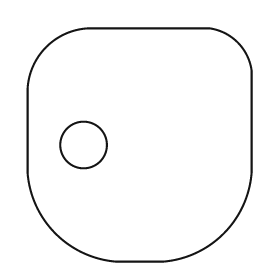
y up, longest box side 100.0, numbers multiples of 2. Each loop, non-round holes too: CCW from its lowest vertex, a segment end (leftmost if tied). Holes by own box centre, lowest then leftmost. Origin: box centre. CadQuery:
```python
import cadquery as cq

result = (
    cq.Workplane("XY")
    .moveTo(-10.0, -50.0)
    .lineTo(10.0, -50.0)
    .threePointArc((36.0, -38.0), (48.0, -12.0))
    .lineTo(48.0, 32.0)
    .threePointArc((42.0, 44.0), (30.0, 50.0))
    .lineTo(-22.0, 50.0)
    .threePointArc((-40.0, 42.0), (-48.0, 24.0))
    .lineTo(-48.0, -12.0)
    .threePointArc((-36.0, -38.0), (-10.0, -50.0))
    .close()
    .moveTo(-24.0, 0.0)
    .circle(10.0)
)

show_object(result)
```